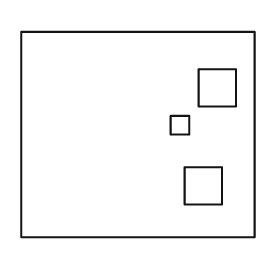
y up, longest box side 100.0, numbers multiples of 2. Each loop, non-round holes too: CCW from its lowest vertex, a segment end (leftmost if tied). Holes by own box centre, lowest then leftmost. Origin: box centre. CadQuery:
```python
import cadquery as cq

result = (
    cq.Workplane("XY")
    .moveTo(-50.0, -44.0)
    .lineTo(50.0, -44.0)
    .lineTo(50.0, 44.0)
    .lineTo(-50.0, 44.0)
    .close()
    .moveTo(20.0, -30.0)
    .lineTo(36.0, -30.0)
    .lineTo(36.0, -14.0)
    .lineTo(20.0, -14.0)
    .close()
    .moveTo(14.0, 0.0)
    .lineTo(22.0, 0.0)
    .lineTo(22.0, 8.0)
    .lineTo(14.0, 8.0)
    .close()
    .moveTo(26.0, 12.0)
    .lineTo(42.0, 12.0)
    .lineTo(42.0, 28.0)
    .lineTo(26.0, 28.0)
    .close()
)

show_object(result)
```